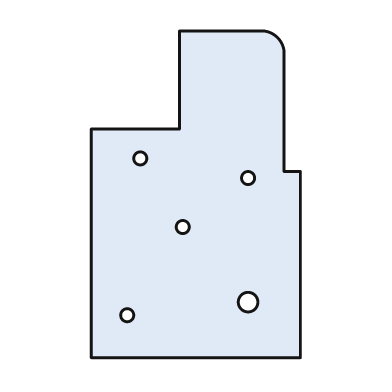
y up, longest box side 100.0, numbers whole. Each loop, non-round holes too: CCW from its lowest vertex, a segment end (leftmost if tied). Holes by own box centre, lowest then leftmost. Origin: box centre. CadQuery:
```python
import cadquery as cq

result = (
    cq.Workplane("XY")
    .moveTo(-32.0, -50.0)
    .lineTo(32.0, -50.0)
    .lineTo(32.0, 7.0)
    .lineTo(27.0, 7.0)
    .lineTo(27.0, 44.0)
    .threePointArc((25.0, 48.0), (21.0, 50.0))
    .lineTo(-5.0, 50.0)
    .lineTo(-5.0, 20.0)
    .lineTo(-32.0, 20.0)
    .close()
    .moveTo(-21.0, -37.0)
    .circle(2.0)
    .moveTo(16.0, -33.0)
    .circle(3.0)
    .moveTo(-4.0, -10.0)
    .circle(2.0)
    .moveTo(16.0, 5.0)
    .circle(2.0)
    .moveTo(-17.0, 11.0)
    .circle(2.0)
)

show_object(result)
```